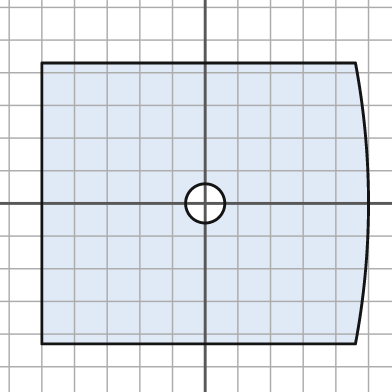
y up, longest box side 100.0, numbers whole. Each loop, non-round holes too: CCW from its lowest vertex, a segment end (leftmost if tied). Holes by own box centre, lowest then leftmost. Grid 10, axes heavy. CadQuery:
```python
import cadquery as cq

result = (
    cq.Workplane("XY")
    .moveTo(-50.0, -43.0)
    .lineTo(46.0, -43.0)
    .threePointArc((50.0, 0.0), (46.0, 43.0))
    .lineTo(-50.0, 43.0)
    .close()
    .moveTo(0.0, 0.0)
    .circle(6.0)
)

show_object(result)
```